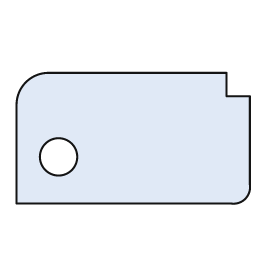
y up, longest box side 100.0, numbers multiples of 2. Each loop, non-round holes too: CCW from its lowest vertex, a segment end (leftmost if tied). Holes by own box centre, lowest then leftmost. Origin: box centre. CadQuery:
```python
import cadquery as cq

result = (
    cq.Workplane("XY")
    .moveTo(-50.0, -28.0)
    .lineTo(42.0, -28.0)
    .threePointArc((48.0, -26.0), (50.0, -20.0))
    .lineTo(50.0, 18.0)
    .lineTo(40.0, 18.0)
    .lineTo(40.0, 28.0)
    .lineTo(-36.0, 28.0)
    .threePointArc((-46.0, 24.0), (-50.0, 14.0))
    .close()
    .moveTo(-32.0, -8.0)
    .circle(8.0)
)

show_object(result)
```